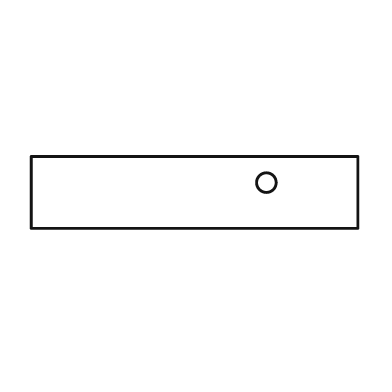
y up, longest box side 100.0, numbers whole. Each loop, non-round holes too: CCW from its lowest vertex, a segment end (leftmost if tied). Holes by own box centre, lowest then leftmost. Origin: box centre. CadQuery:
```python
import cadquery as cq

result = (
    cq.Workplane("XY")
    .moveTo(-50.0, -11.0)
    .lineTo(50.0, -11.0)
    .lineTo(50.0, 11.0)
    .lineTo(-50.0, 11.0)
    .close()
    .moveTo(22.0, 3.0)
    .circle(3.0)
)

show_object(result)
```